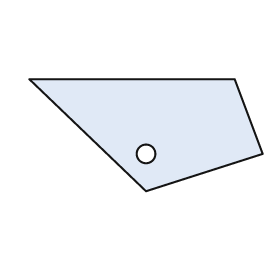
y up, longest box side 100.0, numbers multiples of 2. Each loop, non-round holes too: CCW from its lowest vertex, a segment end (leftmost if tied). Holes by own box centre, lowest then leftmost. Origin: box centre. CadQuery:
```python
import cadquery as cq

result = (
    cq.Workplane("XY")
    .moveTo(0.0, -24.0)
    .lineTo(50.0, -8.0)
    .lineTo(38.0, 24.0)
    .lineTo(-50.0, 24.0)
    .close()
    .moveTo(0.0, -8.0)
    .circle(4.0)
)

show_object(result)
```